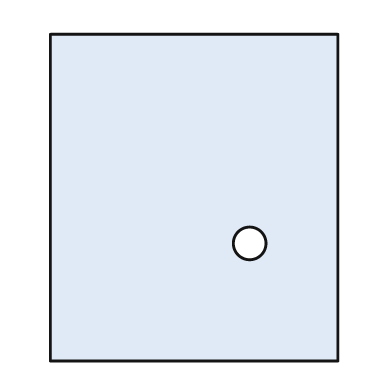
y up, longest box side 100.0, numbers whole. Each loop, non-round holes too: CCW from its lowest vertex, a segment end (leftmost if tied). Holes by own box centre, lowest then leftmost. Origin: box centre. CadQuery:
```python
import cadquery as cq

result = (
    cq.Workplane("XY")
    .moveTo(-44.0, -50.0)
    .lineTo(44.0, -50.0)
    .lineTo(44.0, 50.0)
    .lineTo(-44.0, 50.0)
    .close()
    .moveTo(17.0, -14.0)
    .circle(5.0)
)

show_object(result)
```